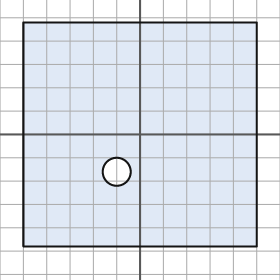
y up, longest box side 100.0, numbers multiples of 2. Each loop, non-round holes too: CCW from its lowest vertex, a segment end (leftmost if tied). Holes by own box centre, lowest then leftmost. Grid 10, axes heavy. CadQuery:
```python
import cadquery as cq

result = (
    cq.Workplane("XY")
    .moveTo(-50.0, -48.0)
    .lineTo(50.0, -48.0)
    .lineTo(50.0, 48.0)
    .lineTo(-50.0, 48.0)
    .close()
    .moveTo(-10.0, -16.0)
    .circle(6.0)
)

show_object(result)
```